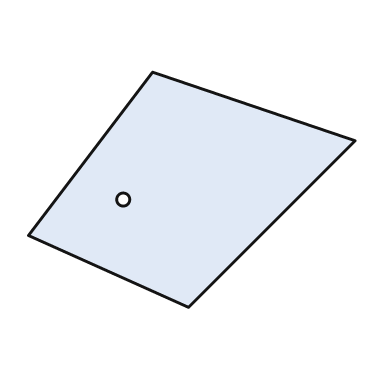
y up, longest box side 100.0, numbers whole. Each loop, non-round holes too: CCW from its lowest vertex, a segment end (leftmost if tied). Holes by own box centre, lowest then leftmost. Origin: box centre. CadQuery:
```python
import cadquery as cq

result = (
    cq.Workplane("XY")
    .moveTo(-1.0, -36.0)
    .lineTo(50.0, 15.0)
    .lineTo(-12.0, 36.0)
    .lineTo(-50.0, -14.0)
    .close()
    .moveTo(-21.0, -3.0)
    .circle(2.0)
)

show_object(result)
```